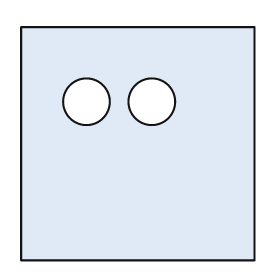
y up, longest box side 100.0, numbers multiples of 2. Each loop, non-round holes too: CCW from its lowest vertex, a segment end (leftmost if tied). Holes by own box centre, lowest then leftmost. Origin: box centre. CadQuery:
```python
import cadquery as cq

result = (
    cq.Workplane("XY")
    .moveTo(-50.0, -50.0)
    .lineTo(50.0, -50.0)
    .lineTo(50.0, 50.0)
    .lineTo(-50.0, 50.0)
    .close()
    .moveTo(-22.0, 18.0)
    .circle(10.0)
    .moveTo(6.0, 18.0)
    .circle(10.0)
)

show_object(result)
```